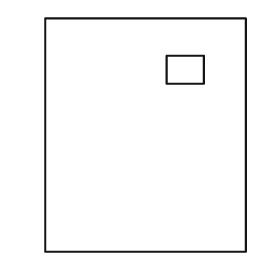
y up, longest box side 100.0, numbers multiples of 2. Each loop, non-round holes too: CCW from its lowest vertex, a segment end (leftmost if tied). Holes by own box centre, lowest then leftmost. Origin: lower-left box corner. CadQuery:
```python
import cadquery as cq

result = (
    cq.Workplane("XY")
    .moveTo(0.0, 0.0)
    .lineTo(86.0, 0.0)
    .lineTo(86.0, 100.0)
    .lineTo(0.0, 100.0)
    .close()
    .moveTo(52.0, 72.0)
    .lineTo(68.0, 72.0)
    .lineTo(68.0, 84.0)
    .lineTo(52.0, 84.0)
    .close()
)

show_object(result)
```